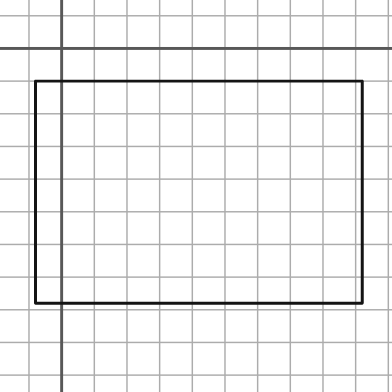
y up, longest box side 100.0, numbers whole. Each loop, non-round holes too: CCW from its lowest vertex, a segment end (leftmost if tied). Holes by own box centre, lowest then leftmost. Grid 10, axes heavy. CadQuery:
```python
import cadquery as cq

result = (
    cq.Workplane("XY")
    .moveTo(-8.0, -78.0)
    .lineTo(92.0, -78.0)
    .lineTo(92.0, -10.0)
    .lineTo(-8.0, -10.0)
    .close()
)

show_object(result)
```